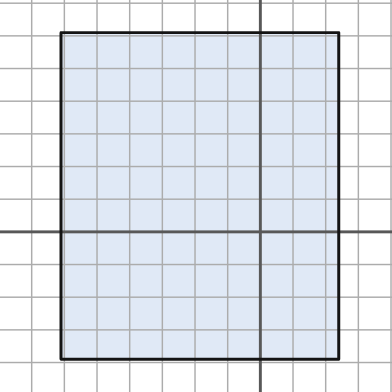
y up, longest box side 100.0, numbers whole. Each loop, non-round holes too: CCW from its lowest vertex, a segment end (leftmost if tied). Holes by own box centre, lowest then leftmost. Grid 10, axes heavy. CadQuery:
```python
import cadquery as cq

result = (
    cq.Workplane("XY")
    .moveTo(-61.0, -39.0)
    .lineTo(24.0, -39.0)
    .lineTo(24.0, 61.0)
    .lineTo(-61.0, 61.0)
    .close()
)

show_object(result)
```